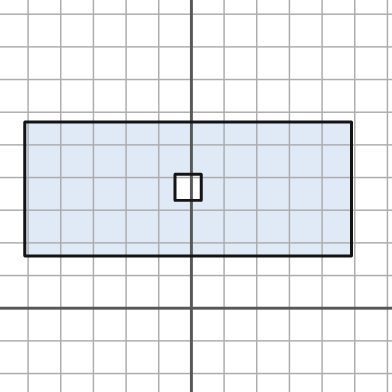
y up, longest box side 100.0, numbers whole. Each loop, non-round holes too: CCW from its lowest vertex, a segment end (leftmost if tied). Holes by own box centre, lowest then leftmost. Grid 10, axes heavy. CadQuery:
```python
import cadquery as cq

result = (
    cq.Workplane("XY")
    .moveTo(-51.0, 16.0)
    .lineTo(49.0, 16.0)
    .lineTo(49.0, 57.0)
    .lineTo(-51.0, 57.0)
    .close()
    .moveTo(-5.0, 33.0)
    .lineTo(3.0, 33.0)
    .lineTo(3.0, 41.0)
    .lineTo(-5.0, 41.0)
    .close()
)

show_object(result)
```